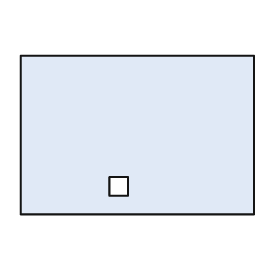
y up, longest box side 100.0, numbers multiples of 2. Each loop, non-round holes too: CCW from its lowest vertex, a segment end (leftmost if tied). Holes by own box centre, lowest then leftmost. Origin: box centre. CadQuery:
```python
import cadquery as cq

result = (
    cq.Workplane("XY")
    .moveTo(-50.0, -34.0)
    .lineTo(50.0, -34.0)
    .lineTo(50.0, 34.0)
    .lineTo(-50.0, 34.0)
    .close()
    .moveTo(-12.0, -26.0)
    .lineTo(-4.0, -26.0)
    .lineTo(-4.0, -18.0)
    .lineTo(-12.0, -18.0)
    .close()
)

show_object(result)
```